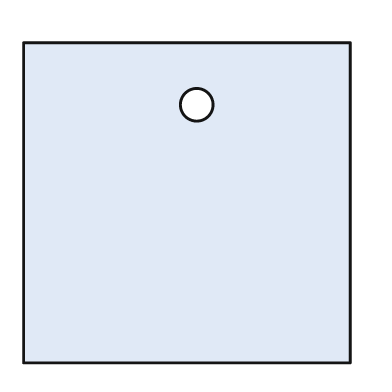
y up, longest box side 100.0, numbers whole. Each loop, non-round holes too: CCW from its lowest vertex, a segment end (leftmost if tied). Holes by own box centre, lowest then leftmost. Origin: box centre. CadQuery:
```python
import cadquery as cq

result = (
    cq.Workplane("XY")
    .moveTo(-50.0, -49.0)
    .lineTo(50.0, -49.0)
    .lineTo(50.0, 49.0)
    .lineTo(-50.0, 49.0)
    .close()
    .moveTo(3.0, 30.0)
    .circle(5.0)
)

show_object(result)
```